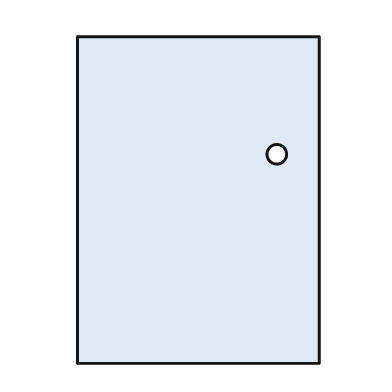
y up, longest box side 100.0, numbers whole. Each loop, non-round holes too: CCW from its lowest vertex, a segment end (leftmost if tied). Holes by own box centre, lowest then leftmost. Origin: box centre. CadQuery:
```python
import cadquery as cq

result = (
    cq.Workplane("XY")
    .moveTo(-37.0, -50.0)
    .lineTo(37.0, -50.0)
    .lineTo(37.0, 50.0)
    .lineTo(-37.0, 50.0)
    .close()
    .moveTo(24.0, 14.0)
    .circle(3.0)
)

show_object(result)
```